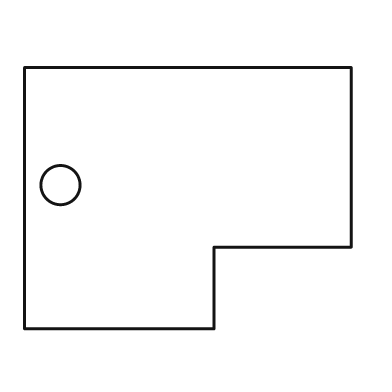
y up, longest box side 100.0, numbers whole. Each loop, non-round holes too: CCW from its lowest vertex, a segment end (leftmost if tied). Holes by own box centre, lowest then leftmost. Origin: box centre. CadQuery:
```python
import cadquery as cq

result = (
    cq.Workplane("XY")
    .moveTo(-50.0, -40.0)
    .lineTo(8.0, -40.0)
    .lineTo(8.0, -15.0)
    .lineTo(50.0, -15.0)
    .lineTo(50.0, 40.0)
    .lineTo(-50.0, 40.0)
    .close()
    .moveTo(-39.0, 4.0)
    .circle(6.0)
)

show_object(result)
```